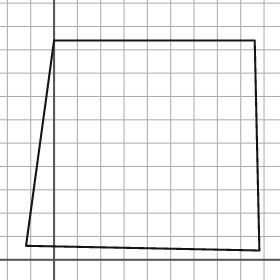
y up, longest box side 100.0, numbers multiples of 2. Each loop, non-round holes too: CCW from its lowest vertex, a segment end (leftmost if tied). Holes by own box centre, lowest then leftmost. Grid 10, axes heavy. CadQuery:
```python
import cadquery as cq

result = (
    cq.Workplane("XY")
    .moveTo(88.0, 4.0)
    .lineTo(86.0, 94.0)
    .lineTo(0.0, 94.0)
    .lineTo(-12.0, 6.0)
    .close()
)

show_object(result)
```